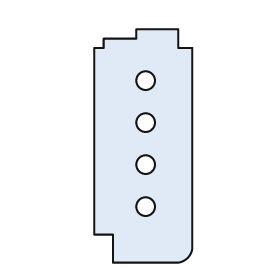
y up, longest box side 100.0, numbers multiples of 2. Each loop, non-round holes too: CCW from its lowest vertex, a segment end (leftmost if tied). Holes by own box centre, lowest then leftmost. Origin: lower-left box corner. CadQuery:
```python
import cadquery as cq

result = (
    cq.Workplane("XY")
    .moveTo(8.0, 0.0)
    .lineTo(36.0, 0.0)
    .threePointArc((40.0, 2.0), (42.0, 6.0))
    .lineTo(42.0, 92.0)
    .lineTo(36.0, 92.0)
    .lineTo(36.0, 100.0)
    .lineTo(18.0, 100.0)
    .lineTo(18.0, 96.0)
    .lineTo(4.0, 96.0)
    .lineTo(4.0, 92.0)
    .lineTo(0.0, 92.0)
    .lineTo(0.0, 12.0)
    .lineTo(8.0, 12.0)
    .close()
    .moveTo(22.0, 24.0)
    .circle(4.0)
    .moveTo(22.0, 42.0)
    .circle(4.0)
    .moveTo(22.0, 60.0)
    .circle(4.0)
    .moveTo(22.0, 78.0)
    .circle(4.0)
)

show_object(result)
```